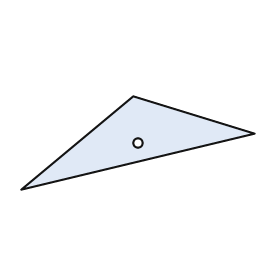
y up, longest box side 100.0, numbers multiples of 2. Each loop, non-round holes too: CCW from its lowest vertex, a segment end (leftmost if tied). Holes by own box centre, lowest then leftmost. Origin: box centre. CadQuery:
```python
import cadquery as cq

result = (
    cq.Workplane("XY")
    .moveTo(-50.0, -20.0)
    .lineTo(50.0, 4.0)
    .lineTo(-2.0, 20.0)
    .close()
    .moveTo(0.0, 0.0)
    .circle(2.0)
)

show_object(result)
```